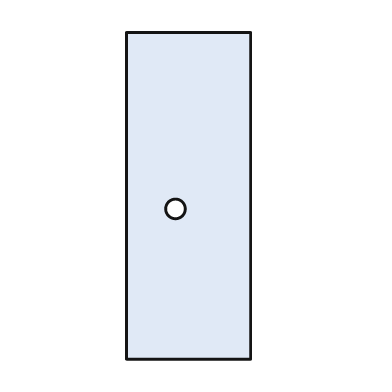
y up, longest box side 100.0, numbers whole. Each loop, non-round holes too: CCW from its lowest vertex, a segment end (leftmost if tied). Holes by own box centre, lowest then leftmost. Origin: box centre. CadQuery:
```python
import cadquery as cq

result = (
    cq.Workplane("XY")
    .moveTo(-19.0, -50.0)
    .lineTo(19.0, -50.0)
    .lineTo(19.0, 50.0)
    .lineTo(-19.0, 50.0)
    .close()
    .moveTo(-4.0, -4.0)
    .circle(3.0)
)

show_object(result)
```